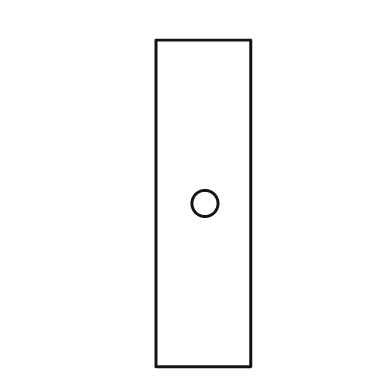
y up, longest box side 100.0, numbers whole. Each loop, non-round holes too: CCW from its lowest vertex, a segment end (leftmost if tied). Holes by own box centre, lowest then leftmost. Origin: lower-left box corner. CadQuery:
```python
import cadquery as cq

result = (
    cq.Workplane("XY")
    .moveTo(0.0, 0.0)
    .lineTo(29.0, 0.0)
    .lineTo(29.0, 100.0)
    .lineTo(0.0, 100.0)
    .close()
    .moveTo(15.0, 50.0)
    .circle(4.0)
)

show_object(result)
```